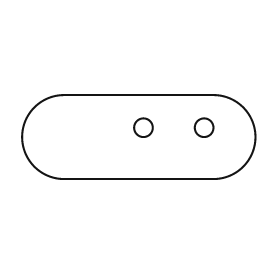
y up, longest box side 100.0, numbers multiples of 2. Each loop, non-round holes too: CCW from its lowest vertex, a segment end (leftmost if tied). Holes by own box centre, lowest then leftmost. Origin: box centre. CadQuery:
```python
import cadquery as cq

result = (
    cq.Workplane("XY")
    .moveTo(-32.0, -18.0)
    .lineTo(32.0, -18.0)
    .threePointArc((50.0, 0.0), (32.0, 18.0))
    .lineTo(-32.0, 18.0)
    .threePointArc((-50.0, 0.0), (-32.0, -18.0))
    .close()
    .moveTo(2.0, 4.0)
    .circle(4.0)
    .moveTo(28.0, 4.0)
    .circle(4.0)
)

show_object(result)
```